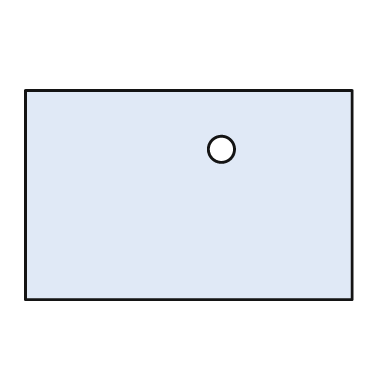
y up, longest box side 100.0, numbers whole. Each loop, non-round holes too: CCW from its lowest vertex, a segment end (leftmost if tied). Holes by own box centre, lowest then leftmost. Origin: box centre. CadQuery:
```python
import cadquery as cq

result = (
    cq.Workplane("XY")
    .moveTo(-50.0, -32.0)
    .lineTo(50.0, -32.0)
    .lineTo(50.0, 32.0)
    .lineTo(-50.0, 32.0)
    .close()
    .moveTo(10.0, 14.0)
    .circle(4.0)
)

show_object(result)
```